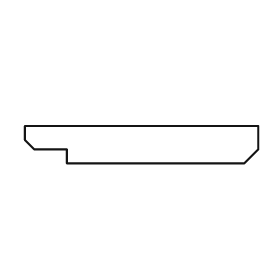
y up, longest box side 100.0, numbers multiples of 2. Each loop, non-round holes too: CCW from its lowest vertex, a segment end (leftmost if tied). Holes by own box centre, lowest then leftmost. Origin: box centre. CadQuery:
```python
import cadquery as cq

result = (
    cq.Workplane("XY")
    .moveTo(-32.0, -8.0)
    .lineTo(44.0, -8.0)
    .lineTo(50.0, -2.0)
    .lineTo(50.0, 8.0)
    .lineTo(-50.0, 8.0)
    .lineTo(-50.0, 2.0)
    .lineTo(-46.0, -2.0)
    .lineTo(-32.0, -2.0)
    .close()
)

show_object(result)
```